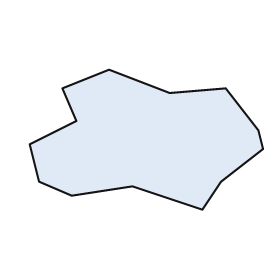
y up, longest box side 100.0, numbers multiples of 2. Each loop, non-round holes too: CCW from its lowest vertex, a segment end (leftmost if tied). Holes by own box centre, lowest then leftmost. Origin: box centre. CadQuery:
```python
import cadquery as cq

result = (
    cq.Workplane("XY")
    .moveTo(24.0, -30.0)
    .lineTo(32.0, -18.0)
    .lineTo(50.0, -4.0)
    .lineTo(48.0, 4.0)
    .lineTo(34.0, 22.0)
    .lineTo(10.0, 20.0)
    .lineTo(-16.0, 30.0)
    .lineTo(-36.0, 22.0)
    .lineTo(-30.0, 8.0)
    .lineTo(-50.0, -2.0)
    .lineTo(-46.0, -18.0)
    .lineTo(-32.0, -24.0)
    .lineTo(-6.0, -20.0)
    .close()
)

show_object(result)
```